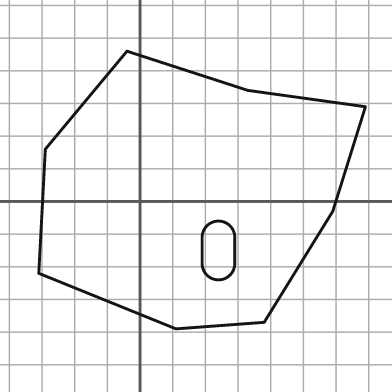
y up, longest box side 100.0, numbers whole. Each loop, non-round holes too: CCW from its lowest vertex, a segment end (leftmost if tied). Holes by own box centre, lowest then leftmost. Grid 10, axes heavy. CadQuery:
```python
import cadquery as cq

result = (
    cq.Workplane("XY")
    .moveTo(11.0, -39.0)
    .lineTo(38.0, -37.0)
    .lineTo(59.0, -3.0)
    .lineTo(69.0, 29.0)
    .lineTo(33.0, 34.0)
    .lineTo(-4.0, 46.0)
    .lineTo(-29.0, 16.0)
    .lineTo(-31.0, -22.0)
    .close()
    .moveTo(19.0, -19.0)
    .threePointArc((24.0, -24.0), (29.0, -19.0))
    .lineTo(29.0, -11.0)
    .threePointArc((24.0, -6.0), (19.0, -11.0))
    .close()
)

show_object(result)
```